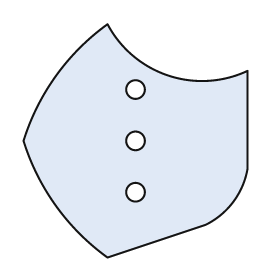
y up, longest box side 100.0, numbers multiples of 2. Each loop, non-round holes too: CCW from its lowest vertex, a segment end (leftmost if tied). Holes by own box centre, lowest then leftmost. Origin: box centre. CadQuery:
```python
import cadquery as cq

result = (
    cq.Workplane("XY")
    .moveTo(-12.0, -50.0)
    .lineTo(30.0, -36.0)
    .threePointArc((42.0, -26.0), (48.0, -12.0))
    .lineTo(48.0, 30.0)
    .threePointArc((14.0, 28.0), (-12.0, 50.0))
    .threePointArc((-34.0, 28.0), (-48.0, 0.0))
    .threePointArc((-34.0, -28.0), (-12.0, -50.0))
    .close()
    .moveTo(0.0, -22.0)
    .circle(4.0)
    .moveTo(0.0, 0.0)
    .circle(4.0)
    .moveTo(0.0, 22.0)
    .circle(4.0)
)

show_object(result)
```